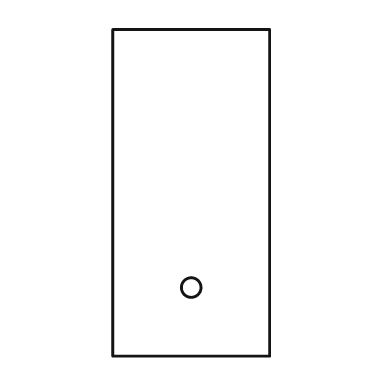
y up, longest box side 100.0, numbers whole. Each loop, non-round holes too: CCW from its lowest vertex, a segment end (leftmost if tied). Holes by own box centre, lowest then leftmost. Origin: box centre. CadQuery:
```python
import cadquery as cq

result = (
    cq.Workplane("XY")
    .moveTo(-24.0, -50.0)
    .lineTo(24.0, -50.0)
    .lineTo(24.0, 50.0)
    .lineTo(-24.0, 50.0)
    .close()
    .moveTo(0.0, -29.0)
    .circle(3.0)
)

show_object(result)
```